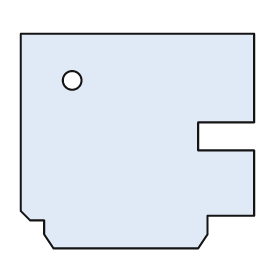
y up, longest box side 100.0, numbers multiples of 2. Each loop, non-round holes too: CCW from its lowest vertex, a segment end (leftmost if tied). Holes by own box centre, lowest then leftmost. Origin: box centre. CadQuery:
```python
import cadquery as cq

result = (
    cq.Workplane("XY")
    .moveTo(-36.0, -46.0)
    .lineTo(26.0, -46.0)
    .lineTo(30.0, -40.0)
    .lineTo(30.0, -32.0)
    .lineTo(50.0, -32.0)
    .lineTo(50.0, -4.0)
    .lineTo(26.0, -4.0)
    .lineTo(26.0, 8.0)
    .lineTo(50.0, 8.0)
    .lineTo(50.0, 46.0)
    .lineTo(-50.0, 46.0)
    .lineTo(-50.0, -30.0)
    .lineTo(-46.0, -34.0)
    .lineTo(-40.0, -34.0)
    .lineTo(-40.0, -40.0)
    .close()
    .moveTo(-28.0, 26.0)
    .circle(4.0)
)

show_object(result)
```